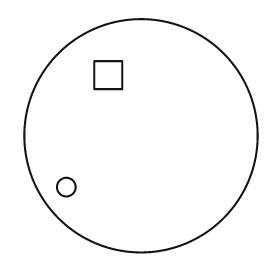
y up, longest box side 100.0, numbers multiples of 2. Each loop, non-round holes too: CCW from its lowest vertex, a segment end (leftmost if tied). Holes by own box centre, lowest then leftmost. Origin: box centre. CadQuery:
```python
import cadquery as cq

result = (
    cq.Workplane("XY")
    .moveTo(0.0, 0.0)
    .circle(50.0)
    .moveTo(-32.0, -22.0)
    .circle(4.0)
    .moveTo(-20.0, 20.0)
    .lineTo(-8.0, 20.0)
    .lineTo(-8.0, 32.0)
    .lineTo(-20.0, 32.0)
    .close()
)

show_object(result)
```